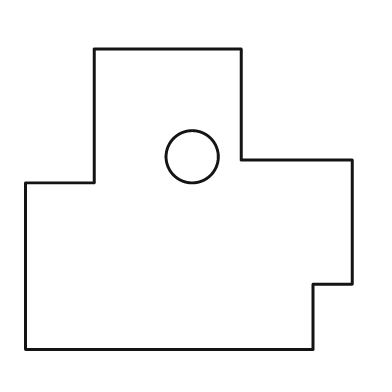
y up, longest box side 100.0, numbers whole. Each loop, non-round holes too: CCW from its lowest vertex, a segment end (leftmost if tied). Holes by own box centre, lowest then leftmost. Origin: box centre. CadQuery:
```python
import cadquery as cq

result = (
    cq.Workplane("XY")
    .moveTo(-50.0, -46.0)
    .lineTo(38.0, -46.0)
    .lineTo(38.0, -26.0)
    .lineTo(50.0, -26.0)
    .lineTo(50.0, 12.0)
    .lineTo(16.0, 12.0)
    .lineTo(16.0, 46.0)
    .lineTo(-29.0, 46.0)
    .lineTo(-29.0, 5.0)
    .lineTo(-50.0, 5.0)
    .close()
    .moveTo(1.0, 13.0)
    .circle(8.0)
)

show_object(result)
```